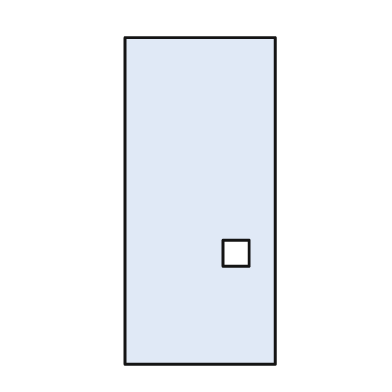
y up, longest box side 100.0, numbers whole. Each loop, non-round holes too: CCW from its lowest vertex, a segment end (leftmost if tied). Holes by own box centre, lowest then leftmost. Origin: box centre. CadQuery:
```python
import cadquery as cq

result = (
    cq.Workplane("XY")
    .moveTo(-23.0, -50.0)
    .lineTo(23.0, -50.0)
    .lineTo(23.0, 50.0)
    .lineTo(-23.0, 50.0)
    .close()
    .moveTo(7.0, -20.0)
    .lineTo(15.0, -20.0)
    .lineTo(15.0, -12.0)
    .lineTo(7.0, -12.0)
    .close()
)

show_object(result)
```